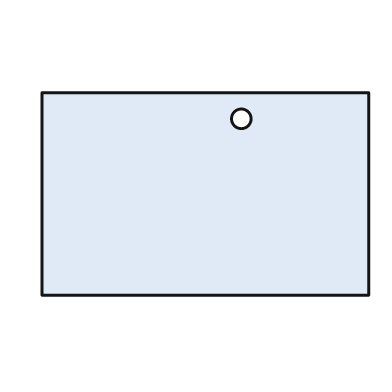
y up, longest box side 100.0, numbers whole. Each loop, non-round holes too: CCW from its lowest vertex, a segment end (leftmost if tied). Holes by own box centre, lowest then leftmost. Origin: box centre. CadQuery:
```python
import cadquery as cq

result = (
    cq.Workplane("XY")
    .moveTo(-50.0, -31.0)
    .lineTo(50.0, -31.0)
    .lineTo(50.0, 31.0)
    .lineTo(-50.0, 31.0)
    .close()
    .moveTo(11.0, 23.0)
    .circle(3.0)
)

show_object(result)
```